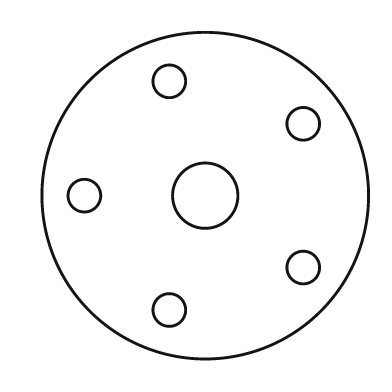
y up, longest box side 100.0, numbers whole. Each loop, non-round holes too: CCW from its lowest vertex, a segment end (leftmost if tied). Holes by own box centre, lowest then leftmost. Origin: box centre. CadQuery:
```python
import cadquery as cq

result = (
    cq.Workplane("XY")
    .moveTo(0.0, 0.0)
    .circle(50.0)
    .moveTo(-11.0, -35.0)
    .circle(5.0)
    .moveTo(30.0, -22.0)
    .circle(5.0)
    .moveTo(-37.0, 0.0)
    .circle(5.0)
    .moveTo(0.0, 0.0)
    .circle(10.0)
    .moveTo(30.0, 22.0)
    .circle(5.0)
    .moveTo(-11.0, 35.0)
    .circle(5.0)
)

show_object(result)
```